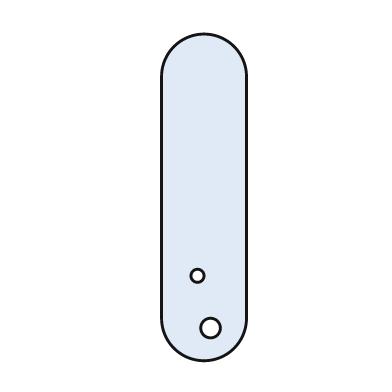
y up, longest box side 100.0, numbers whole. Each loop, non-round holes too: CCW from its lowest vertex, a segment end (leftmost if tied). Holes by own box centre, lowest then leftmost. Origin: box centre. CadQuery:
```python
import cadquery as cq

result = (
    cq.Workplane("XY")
    .moveTo(-13.0, -37.0)
    .threePointArc((0.0, -50.0), (13.0, -37.0))
    .lineTo(13.0, 37.0)
    .threePointArc((0.0, 50.0), (-13.0, 37.0))
    .close()
    .moveTo(2.0, -40.0)
    .circle(3.0)
    .moveTo(-2.0, -24.0)
    .circle(2.0)
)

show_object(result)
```